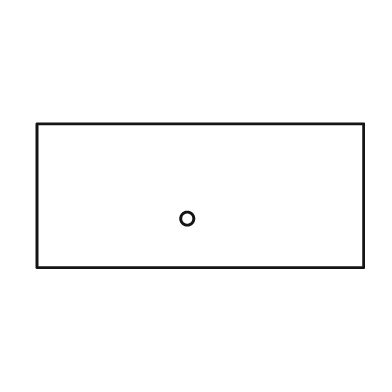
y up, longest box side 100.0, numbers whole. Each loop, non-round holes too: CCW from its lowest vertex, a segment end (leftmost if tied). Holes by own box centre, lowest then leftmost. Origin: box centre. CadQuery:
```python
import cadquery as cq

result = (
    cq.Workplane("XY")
    .moveTo(-50.0, -22.0)
    .lineTo(50.0, -22.0)
    .lineTo(50.0, 22.0)
    .lineTo(-50.0, 22.0)
    .close()
    .moveTo(-4.0, -7.0)
    .circle(2.0)
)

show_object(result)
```